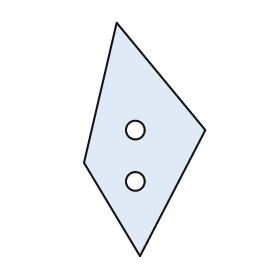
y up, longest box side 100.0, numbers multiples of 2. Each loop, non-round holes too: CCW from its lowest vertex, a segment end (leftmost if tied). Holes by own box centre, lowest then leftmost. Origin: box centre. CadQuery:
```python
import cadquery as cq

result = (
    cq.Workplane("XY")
    .moveTo(-2.0, -50.0)
    .lineTo(26.0, 4.0)
    .lineTo(-12.0, 50.0)
    .lineTo(-26.0, -10.0)
    .close()
    .moveTo(-4.0, -18.0)
    .circle(4.0)
    .moveTo(-4.0, 4.0)
    .circle(4.0)
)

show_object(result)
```